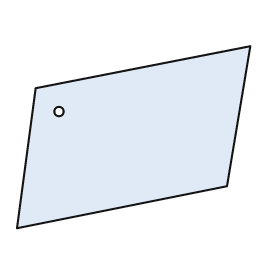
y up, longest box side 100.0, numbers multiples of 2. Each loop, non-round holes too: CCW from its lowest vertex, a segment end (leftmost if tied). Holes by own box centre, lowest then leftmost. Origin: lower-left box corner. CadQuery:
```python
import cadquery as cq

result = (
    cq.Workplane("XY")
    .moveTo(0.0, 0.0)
    .lineTo(90.0, 18.0)
    .lineTo(100.0, 78.0)
    .lineTo(8.0, 60.0)
    .close()
    .moveTo(18.0, 50.0)
    .circle(2.0)
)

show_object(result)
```